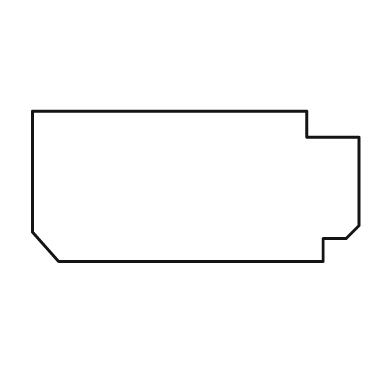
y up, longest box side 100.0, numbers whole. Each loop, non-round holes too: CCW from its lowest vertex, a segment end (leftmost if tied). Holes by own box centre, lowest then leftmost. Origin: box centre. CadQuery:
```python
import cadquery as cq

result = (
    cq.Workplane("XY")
    .moveTo(-42.0, -23.0)
    .lineTo(39.0, -23.0)
    .lineTo(39.0, -16.0)
    .lineTo(46.0, -16.0)
    .lineTo(50.0, -12.0)
    .lineTo(50.0, 15.0)
    .lineTo(34.0, 15.0)
    .lineTo(34.0, 23.0)
    .lineTo(-50.0, 23.0)
    .lineTo(-50.0, -14.0)
    .close()
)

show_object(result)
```